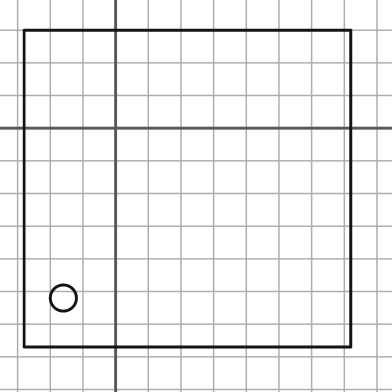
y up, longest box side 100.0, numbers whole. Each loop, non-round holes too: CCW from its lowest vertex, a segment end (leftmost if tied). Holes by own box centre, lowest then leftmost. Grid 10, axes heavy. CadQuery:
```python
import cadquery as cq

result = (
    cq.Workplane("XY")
    .moveTo(-28.0, -67.0)
    .lineTo(72.0, -67.0)
    .lineTo(72.0, 30.0)
    .lineTo(-28.0, 30.0)
    .close()
    .moveTo(-16.0, -52.0)
    .circle(4.0)
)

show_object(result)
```